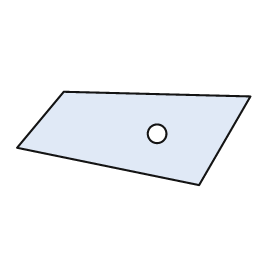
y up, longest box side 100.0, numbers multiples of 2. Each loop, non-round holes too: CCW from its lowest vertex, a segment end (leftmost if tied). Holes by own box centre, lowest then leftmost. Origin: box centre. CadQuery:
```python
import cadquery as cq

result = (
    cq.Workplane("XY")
    .moveTo(28.0, -20.0)
    .lineTo(50.0, 18.0)
    .lineTo(-30.0, 20.0)
    .lineTo(-50.0, -4.0)
    .close()
    .moveTo(10.0, 2.0)
    .circle(4.0)
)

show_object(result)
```